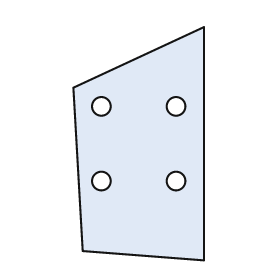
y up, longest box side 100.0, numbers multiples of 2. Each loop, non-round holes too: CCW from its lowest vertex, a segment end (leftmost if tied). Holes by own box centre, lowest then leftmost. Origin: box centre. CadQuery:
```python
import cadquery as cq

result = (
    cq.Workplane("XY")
    .moveTo(28.0, -50.0)
    .lineTo(28.0, 50.0)
    .lineTo(-28.0, 24.0)
    .lineTo(-24.0, -46.0)
    .close()
    .moveTo(-16.0, -16.0)
    .circle(4.0)
    .moveTo(16.0, -16.0)
    .circle(4.0)
    .moveTo(-16.0, 16.0)
    .circle(4.0)
    .moveTo(16.0, 16.0)
    .circle(4.0)
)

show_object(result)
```